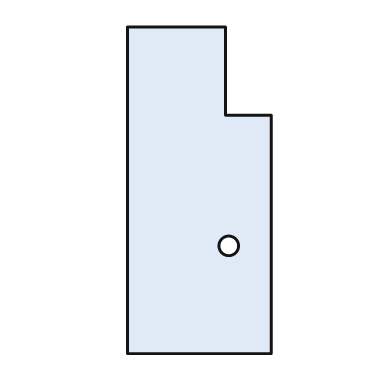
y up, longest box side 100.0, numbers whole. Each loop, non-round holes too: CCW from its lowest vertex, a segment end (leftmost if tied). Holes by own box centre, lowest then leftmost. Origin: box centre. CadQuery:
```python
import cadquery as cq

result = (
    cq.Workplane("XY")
    .moveTo(-22.0, -50.0)
    .lineTo(22.0, -50.0)
    .lineTo(22.0, 23.0)
    .lineTo(8.0, 23.0)
    .lineTo(8.0, 50.0)
    .lineTo(-22.0, 50.0)
    .close()
    .moveTo(9.0, -17.0)
    .circle(3.0)
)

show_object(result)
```